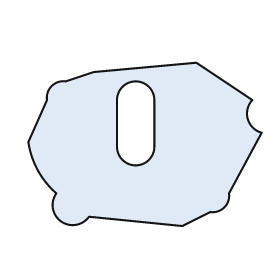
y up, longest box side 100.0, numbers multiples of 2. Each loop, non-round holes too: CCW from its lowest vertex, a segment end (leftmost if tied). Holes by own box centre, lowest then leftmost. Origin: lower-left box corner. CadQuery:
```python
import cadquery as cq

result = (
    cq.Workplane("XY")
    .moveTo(66.0, 0.0)
    .lineTo(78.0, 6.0)
    .threePointArc((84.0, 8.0), (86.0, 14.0))
    .lineTo(100.0, 40.0)
    .threePointArc((94.0, 46.0), (96.0, 54.0))
    .lineTo(72.0, 70.0)
    .lineTo(28.0, 66.0)
    .lineTo(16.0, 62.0)
    .threePointArc((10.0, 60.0), (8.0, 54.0))
    .lineTo(0.0, 36.0)
    .threePointArc((4.0, 24.0), (12.0, 14.0))
    .threePointArc((14.0, 2.0), (26.0, 4.0))
    .close()
    .moveTo(38.0, 34.0)
    .threePointArc((46.0, 26.0), (54.0, 34.0))
    .lineTo(54.0, 54.0)
    .threePointArc((46.0, 62.0), (38.0, 54.0))
    .close()
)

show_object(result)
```